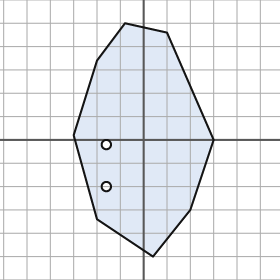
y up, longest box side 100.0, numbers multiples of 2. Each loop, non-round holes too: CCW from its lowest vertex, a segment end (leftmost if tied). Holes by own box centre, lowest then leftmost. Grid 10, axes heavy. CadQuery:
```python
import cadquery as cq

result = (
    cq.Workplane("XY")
    .moveTo(4.0, -50.0)
    .lineTo(20.0, -30.0)
    .lineTo(30.0, 0.0)
    .lineTo(10.0, 46.0)
    .lineTo(-8.0, 50.0)
    .lineTo(-20.0, 34.0)
    .lineTo(-30.0, 2.0)
    .lineTo(-20.0, -34.0)
    .close()
    .moveTo(-16.0, -20.0)
    .circle(2.0)
    .moveTo(-16.0, -2.0)
    .circle(2.0)
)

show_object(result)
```